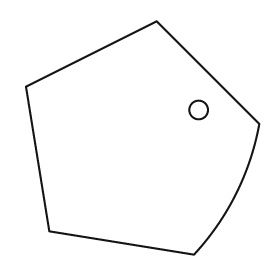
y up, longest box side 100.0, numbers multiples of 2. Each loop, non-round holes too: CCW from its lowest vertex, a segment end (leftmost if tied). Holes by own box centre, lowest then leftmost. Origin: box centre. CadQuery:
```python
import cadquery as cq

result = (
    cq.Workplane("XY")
    .moveTo(22.0, -50.0)
    .threePointArc((40.0, -24.0), (50.0, 6.0))
    .lineTo(6.0, 50.0)
    .lineTo(-50.0, 22.0)
    .lineTo(-40.0, -40.0)
    .close()
    .moveTo(24.0, 12.0)
    .circle(4.0)
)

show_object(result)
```